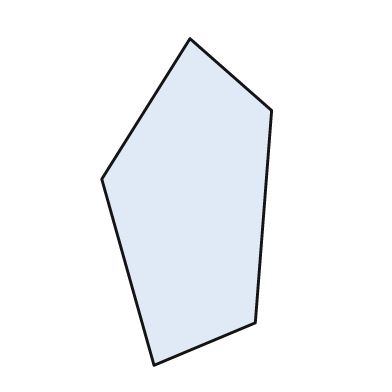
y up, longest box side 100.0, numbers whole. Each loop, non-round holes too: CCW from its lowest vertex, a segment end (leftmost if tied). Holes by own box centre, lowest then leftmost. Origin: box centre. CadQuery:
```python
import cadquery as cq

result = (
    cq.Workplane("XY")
    .moveTo(-10.0, -50.0)
    .lineTo(21.0, -37.0)
    .lineTo(26.0, 28.0)
    .lineTo(1.0, 50.0)
    .lineTo(-26.0, 7.0)
    .close()
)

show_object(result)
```